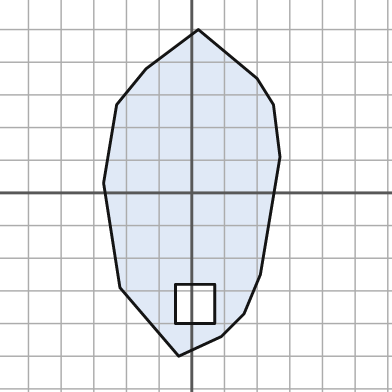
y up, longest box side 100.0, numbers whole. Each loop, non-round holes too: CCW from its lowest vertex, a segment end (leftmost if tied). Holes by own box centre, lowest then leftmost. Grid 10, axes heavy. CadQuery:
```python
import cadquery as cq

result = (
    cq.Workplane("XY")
    .moveTo(-4.0, -50.0)
    .lineTo(9.0, -44.0)
    .lineTo(16.0, -37.0)
    .lineTo(21.0, -25.0)
    .lineTo(27.0, 11.0)
    .lineTo(25.0, 27.0)
    .lineTo(20.0, 35.0)
    .lineTo(2.0, 50.0)
    .lineTo(-14.0, 38.0)
    .lineTo(-23.0, 27.0)
    .lineTo(-27.0, 3.0)
    .lineTo(-22.0, -29.0)
    .close()
    .moveTo(-5.0, -40.0)
    .lineTo(7.0, -40.0)
    .lineTo(7.0, -28.0)
    .lineTo(-5.0, -28.0)
    .close()
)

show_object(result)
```